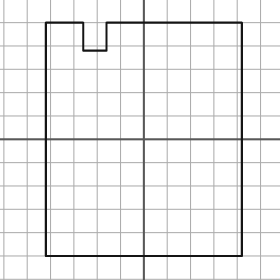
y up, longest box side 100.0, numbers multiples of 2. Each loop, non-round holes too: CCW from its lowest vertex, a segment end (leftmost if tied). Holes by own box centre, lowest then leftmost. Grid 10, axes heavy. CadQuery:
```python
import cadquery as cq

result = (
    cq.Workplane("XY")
    .moveTo(-42.0, -50.0)
    .lineTo(42.0, -50.0)
    .lineTo(42.0, 50.0)
    .lineTo(-16.0, 50.0)
    .lineTo(-16.0, 38.0)
    .lineTo(-26.0, 38.0)
    .lineTo(-26.0, 50.0)
    .lineTo(-42.0, 50.0)
    .close()
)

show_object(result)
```